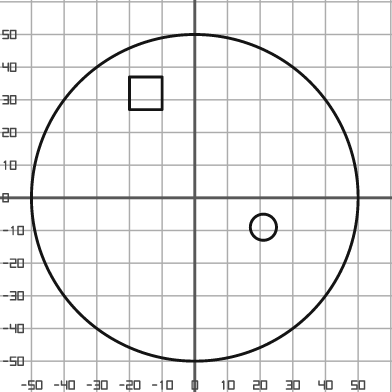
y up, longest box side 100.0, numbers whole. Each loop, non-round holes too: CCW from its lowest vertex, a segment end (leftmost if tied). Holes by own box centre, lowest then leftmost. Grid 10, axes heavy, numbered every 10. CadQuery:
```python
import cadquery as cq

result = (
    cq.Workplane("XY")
    .moveTo(0.0, 0.0)
    .circle(50.0)
    .moveTo(21.0, -9.0)
    .circle(4.0)
    .moveTo(-20.0, 27.0)
    .lineTo(-10.0, 27.0)
    .lineTo(-10.0, 37.0)
    .lineTo(-20.0, 37.0)
    .close()
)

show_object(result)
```